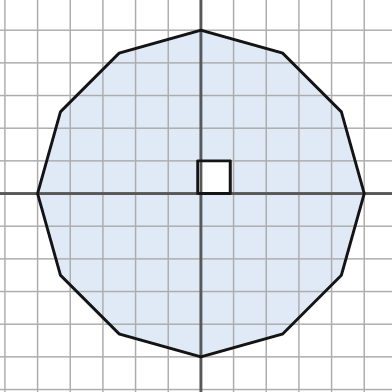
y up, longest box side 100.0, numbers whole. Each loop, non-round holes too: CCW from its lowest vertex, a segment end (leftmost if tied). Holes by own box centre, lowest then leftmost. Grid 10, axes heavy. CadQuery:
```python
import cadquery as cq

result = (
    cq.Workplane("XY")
    .moveTo(0.0, -50.0)
    .lineTo(25.0, -43.0)
    .lineTo(43.0, -25.0)
    .lineTo(50.0, 0.0)
    .lineTo(43.0, 25.0)
    .lineTo(25.0, 43.0)
    .lineTo(0.0, 50.0)
    .lineTo(-25.0, 43.0)
    .lineTo(-43.0, 25.0)
    .lineTo(-50.0, 0.0)
    .lineTo(-43.0, -25.0)
    .lineTo(-25.0, -43.0)
    .close()
    .moveTo(-1.0, 0.0)
    .lineTo(9.0, 0.0)
    .lineTo(9.0, 10.0)
    .lineTo(-1.0, 10.0)
    .close()
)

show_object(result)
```